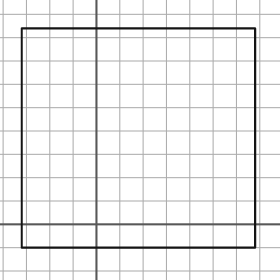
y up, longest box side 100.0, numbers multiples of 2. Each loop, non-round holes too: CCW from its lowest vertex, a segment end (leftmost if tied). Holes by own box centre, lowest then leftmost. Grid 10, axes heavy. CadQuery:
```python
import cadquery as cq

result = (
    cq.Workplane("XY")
    .moveTo(-32.0, -10.0)
    .lineTo(68.0, -10.0)
    .lineTo(68.0, 84.0)
    .lineTo(-32.0, 84.0)
    .close()
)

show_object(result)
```